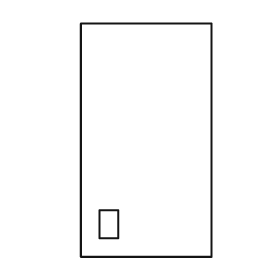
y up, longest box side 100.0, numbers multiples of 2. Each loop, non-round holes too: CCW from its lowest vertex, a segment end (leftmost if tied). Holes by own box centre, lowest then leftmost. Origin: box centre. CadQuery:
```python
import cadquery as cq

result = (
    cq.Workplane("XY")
    .moveTo(-28.0, -50.0)
    .lineTo(28.0, -50.0)
    .lineTo(28.0, 50.0)
    .lineTo(-28.0, 50.0)
    .close()
    .moveTo(-20.0, -42.0)
    .lineTo(-12.0, -42.0)
    .lineTo(-12.0, -30.0)
    .lineTo(-20.0, -30.0)
    .close()
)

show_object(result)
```